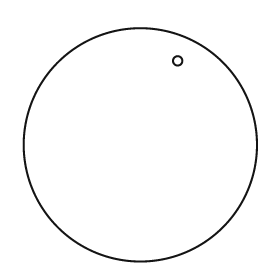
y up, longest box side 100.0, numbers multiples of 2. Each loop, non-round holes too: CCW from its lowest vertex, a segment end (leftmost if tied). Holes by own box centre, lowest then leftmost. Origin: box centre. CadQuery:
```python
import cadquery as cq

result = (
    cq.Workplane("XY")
    .moveTo(0.0, 0.0)
    .circle(50.0)
    .moveTo(16.0, 36.0)
    .circle(2.0)
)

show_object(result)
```